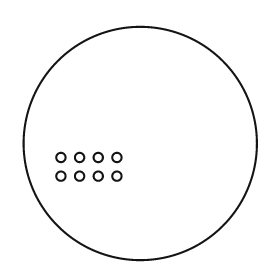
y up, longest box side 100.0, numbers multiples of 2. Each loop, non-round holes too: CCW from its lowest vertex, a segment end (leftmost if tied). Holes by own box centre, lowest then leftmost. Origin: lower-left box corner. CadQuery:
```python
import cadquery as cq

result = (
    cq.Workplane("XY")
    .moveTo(50.0, 50.0)
    .circle(50.0)
    .moveTo(16.0, 36.0)
    .circle(2.0)
    .moveTo(24.0, 36.0)
    .circle(2.0)
    .moveTo(32.0, 36.0)
    .circle(2.0)
    .moveTo(40.0, 36.0)
    .circle(2.0)
    .moveTo(16.0, 44.0)
    .circle(2.0)
    .moveTo(24.0, 44.0)
    .circle(2.0)
    .moveTo(32.0, 44.0)
    .circle(2.0)
    .moveTo(40.0, 44.0)
    .circle(2.0)
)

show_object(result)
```